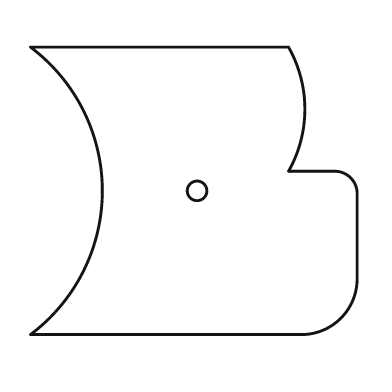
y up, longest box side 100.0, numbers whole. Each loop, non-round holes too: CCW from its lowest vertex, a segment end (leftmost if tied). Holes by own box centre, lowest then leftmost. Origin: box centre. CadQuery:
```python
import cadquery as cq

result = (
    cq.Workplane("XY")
    .moveTo(-50.0, -44.0)
    .lineTo(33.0, -44.0)
    .threePointArc((45.0, -39.0), (50.0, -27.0))
    .lineTo(50.0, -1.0)
    .threePointArc((48.0, 4.0), (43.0, 6.0))
    .lineTo(29.0, 6.0)
    .threePointArc((34.0, 25.0), (29.0, 44.0))
    .lineTo(-50.0, 44.0)
    .threePointArc((-28.0, 0.0), (-50.0, -44.0))
    .close()
    .moveTo(1.0, 0.0)
    .circle(3.0)
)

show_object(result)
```